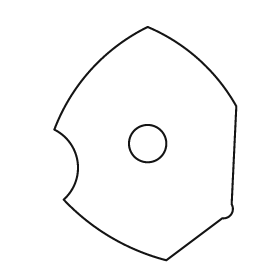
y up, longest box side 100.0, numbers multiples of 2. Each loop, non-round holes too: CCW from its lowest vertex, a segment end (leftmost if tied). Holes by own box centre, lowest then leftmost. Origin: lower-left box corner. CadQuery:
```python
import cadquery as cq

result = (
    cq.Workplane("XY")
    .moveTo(48.0, 0.0)
    .lineTo(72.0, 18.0)
    .threePointArc((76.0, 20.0), (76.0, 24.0))
    .lineTo(78.0, 66.0)
    .threePointArc((62.0, 86.0), (40.0, 100.0))
    .threePointArc((16.0, 82.0), (0.0, 56.0))
    .threePointArc((10.0, 42.0), (4.0, 26.0))
    .threePointArc((24.0, 10.0), (48.0, 0.0))
    .close()
    .moveTo(40.0, 50.0)
    .circle(8.0)
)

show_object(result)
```